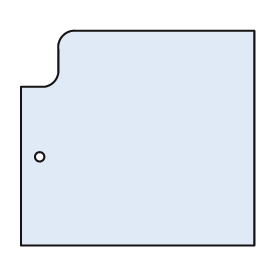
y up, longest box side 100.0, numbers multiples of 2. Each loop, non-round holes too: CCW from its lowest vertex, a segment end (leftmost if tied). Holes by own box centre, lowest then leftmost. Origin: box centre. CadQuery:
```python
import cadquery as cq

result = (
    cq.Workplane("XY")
    .moveTo(-50.0, -46.0)
    .lineTo(50.0, -46.0)
    .lineTo(50.0, 46.0)
    .lineTo(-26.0, 46.0)
    .threePointArc((-32.0, 44.0), (-34.0, 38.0))
    .lineTo(-34.0, 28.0)
    .threePointArc((-36.0, 24.0), (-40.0, 22.0))
    .lineTo(-50.0, 22.0)
    .close()
    .moveTo(-42.0, -8.0)
    .circle(2.0)
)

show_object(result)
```